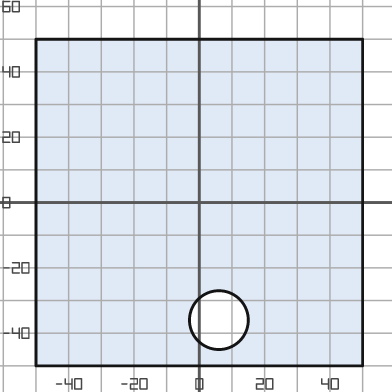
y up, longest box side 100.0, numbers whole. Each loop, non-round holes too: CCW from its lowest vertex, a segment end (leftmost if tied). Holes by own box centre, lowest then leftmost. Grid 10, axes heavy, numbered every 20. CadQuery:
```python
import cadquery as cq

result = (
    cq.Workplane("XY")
    .moveTo(-50.0, -50.0)
    .lineTo(50.0, -50.0)
    .lineTo(50.0, 50.0)
    .lineTo(-50.0, 50.0)
    .close()
    .moveTo(6.0, -36.0)
    .circle(9.0)
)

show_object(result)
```